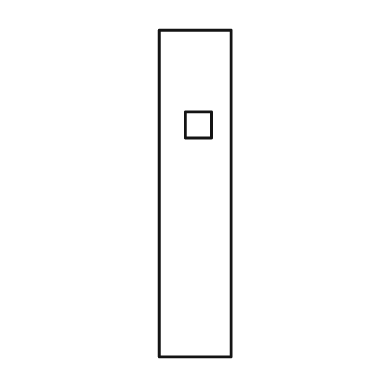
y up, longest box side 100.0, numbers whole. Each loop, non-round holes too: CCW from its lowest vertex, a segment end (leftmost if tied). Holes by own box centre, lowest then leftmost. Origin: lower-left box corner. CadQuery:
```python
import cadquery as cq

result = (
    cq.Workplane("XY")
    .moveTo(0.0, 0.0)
    .lineTo(22.0, 0.0)
    .lineTo(22.0, 100.0)
    .lineTo(0.0, 100.0)
    .close()
    .moveTo(8.0, 67.0)
    .lineTo(16.0, 67.0)
    .lineTo(16.0, 75.0)
    .lineTo(8.0, 75.0)
    .close()
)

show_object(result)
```